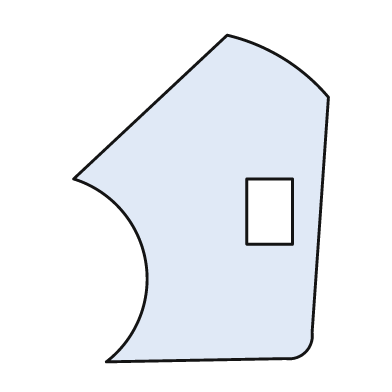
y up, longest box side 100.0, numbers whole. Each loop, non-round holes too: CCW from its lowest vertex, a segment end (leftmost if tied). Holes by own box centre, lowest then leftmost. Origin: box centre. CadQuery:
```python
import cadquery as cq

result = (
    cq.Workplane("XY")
    .moveTo(-29.0, -50.0)
    .lineTo(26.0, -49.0)
    .threePointArc((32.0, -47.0), (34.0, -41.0))
    .lineTo(39.0, 31.0)
    .threePointArc((25.0, 43.0), (8.0, 50.0))
    .lineTo(-39.0, 6.0)
    .threePointArc((-17.0, -19.0), (-29.0, -50.0))
    .close()
    .moveTo(14.0, -14.0)
    .lineTo(28.0, -14.0)
    .lineTo(28.0, 6.0)
    .lineTo(14.0, 6.0)
    .close()
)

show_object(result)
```